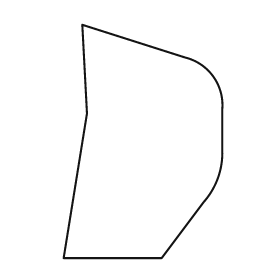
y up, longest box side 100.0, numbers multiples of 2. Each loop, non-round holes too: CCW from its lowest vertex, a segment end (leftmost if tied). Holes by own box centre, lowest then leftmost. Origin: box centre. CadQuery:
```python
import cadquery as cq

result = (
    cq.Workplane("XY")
    .moveTo(-34.0, -50.0)
    .lineTo(8.0, -50.0)
    .lineTo(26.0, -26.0)
    .threePointArc((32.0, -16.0), (34.0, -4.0))
    .lineTo(34.0, 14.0)
    .threePointArc((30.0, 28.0), (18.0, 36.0))
    .lineTo(-26.0, 50.0)
    .lineTo(-24.0, 12.0)
    .close()
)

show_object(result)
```